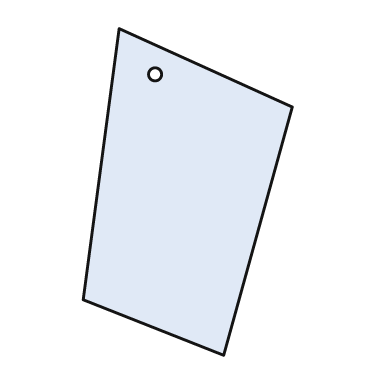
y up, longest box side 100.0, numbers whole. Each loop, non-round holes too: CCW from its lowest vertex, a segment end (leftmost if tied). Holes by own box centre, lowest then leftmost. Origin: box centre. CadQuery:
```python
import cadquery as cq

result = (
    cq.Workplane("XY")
    .moveTo(11.0, -50.0)
    .lineTo(32.0, 26.0)
    .lineTo(-21.0, 50.0)
    .lineTo(-32.0, -33.0)
    .close()
    .moveTo(-10.0, 36.0)
    .circle(2.0)
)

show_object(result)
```